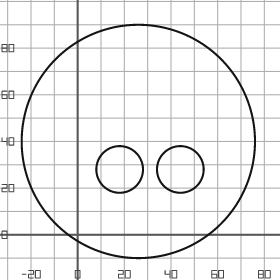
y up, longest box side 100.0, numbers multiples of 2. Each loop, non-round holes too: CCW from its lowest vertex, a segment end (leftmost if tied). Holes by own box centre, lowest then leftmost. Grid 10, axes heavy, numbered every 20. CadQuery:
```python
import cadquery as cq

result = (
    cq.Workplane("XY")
    .moveTo(26.0, 40.0)
    .circle(50.0)
    .moveTo(18.0, 28.0)
    .circle(10.0)
    .moveTo(44.0, 28.0)
    .circle(10.0)
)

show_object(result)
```